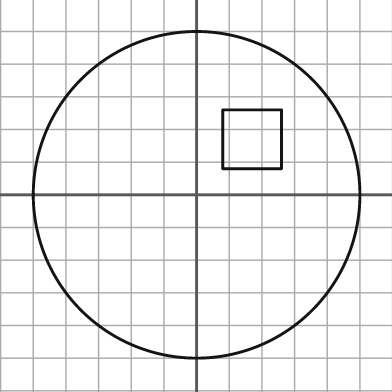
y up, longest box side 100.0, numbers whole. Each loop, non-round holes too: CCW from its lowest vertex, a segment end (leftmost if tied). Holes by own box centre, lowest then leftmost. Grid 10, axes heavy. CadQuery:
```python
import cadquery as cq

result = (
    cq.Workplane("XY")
    .moveTo(0.0, 0.0)
    .circle(50.0)
    .moveTo(8.0, 8.0)
    .lineTo(26.0, 8.0)
    .lineTo(26.0, 26.0)
    .lineTo(8.0, 26.0)
    .close()
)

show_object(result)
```